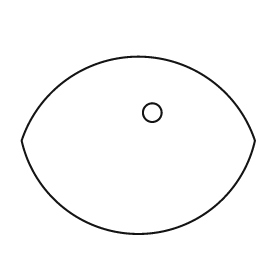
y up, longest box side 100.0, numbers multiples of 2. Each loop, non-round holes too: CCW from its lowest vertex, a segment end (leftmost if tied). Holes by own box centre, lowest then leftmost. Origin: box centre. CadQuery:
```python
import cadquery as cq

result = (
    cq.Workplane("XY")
    .moveTo(-50.0, 2.0)
    .threePointArc((0.0, -38.0), (50.0, 2.0))
    .threePointArc((0.0, 38.0), (-50.0, 2.0))
    .close()
    .moveTo(6.0, 14.0)
    .circle(4.0)
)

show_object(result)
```